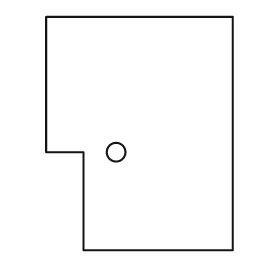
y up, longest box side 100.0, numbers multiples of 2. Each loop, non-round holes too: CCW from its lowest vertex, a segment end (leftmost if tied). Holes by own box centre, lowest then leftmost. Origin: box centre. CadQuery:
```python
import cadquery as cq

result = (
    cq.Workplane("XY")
    .moveTo(-24.0, -50.0)
    .lineTo(40.0, -50.0)
    .lineTo(40.0, 50.0)
    .lineTo(-40.0, 50.0)
    .lineTo(-40.0, -8.0)
    .lineTo(-24.0, -8.0)
    .close()
    .moveTo(-10.0, -8.0)
    .circle(4.0)
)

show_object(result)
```